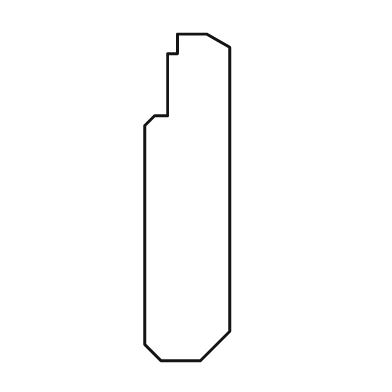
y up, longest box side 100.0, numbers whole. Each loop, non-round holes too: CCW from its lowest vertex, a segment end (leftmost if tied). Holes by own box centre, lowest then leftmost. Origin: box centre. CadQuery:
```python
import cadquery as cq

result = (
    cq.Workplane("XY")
    .moveTo(-8.0, -50.0)
    .lineTo(4.0, -50.0)
    .lineTo(13.0, -41.0)
    .lineTo(13.0, 46.0)
    .lineTo(6.0, 50.0)
    .lineTo(-3.0, 50.0)
    .lineTo(-3.0, 44.0)
    .lineTo(-6.0, 44.0)
    .lineTo(-6.0, 25.0)
    .lineTo(-10.0, 25.0)
    .lineTo(-13.0, 22.0)
    .lineTo(-13.0, -45.0)
    .close()
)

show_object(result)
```